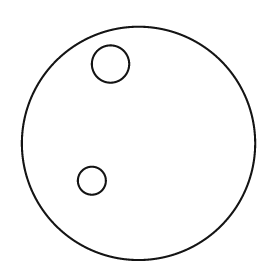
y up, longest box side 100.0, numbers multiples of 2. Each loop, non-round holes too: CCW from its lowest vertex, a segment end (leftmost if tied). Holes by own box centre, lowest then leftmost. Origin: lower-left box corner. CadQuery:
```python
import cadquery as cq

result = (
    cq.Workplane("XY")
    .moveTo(50.0, 50.0)
    .circle(50.0)
    .moveTo(30.0, 34.0)
    .circle(6.0)
    .moveTo(38.0, 84.0)
    .circle(8.0)
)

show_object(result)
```